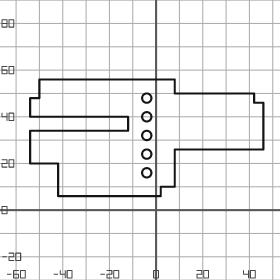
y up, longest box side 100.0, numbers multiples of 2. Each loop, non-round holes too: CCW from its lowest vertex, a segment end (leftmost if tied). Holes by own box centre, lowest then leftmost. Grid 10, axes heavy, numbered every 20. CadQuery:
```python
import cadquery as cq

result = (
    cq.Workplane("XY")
    .moveTo(-42.0, 6.0)
    .lineTo(2.0, 6.0)
    .lineTo(2.0, 10.0)
    .lineTo(8.0, 10.0)
    .lineTo(8.0, 26.0)
    .lineTo(46.0, 26.0)
    .lineTo(46.0, 46.0)
    .lineTo(42.0, 46.0)
    .lineTo(42.0, 50.0)
    .lineTo(8.0, 50.0)
    .lineTo(8.0, 56.0)
    .lineTo(-50.0, 56.0)
    .lineTo(-50.0, 48.0)
    .lineTo(-54.0, 48.0)
    .lineTo(-54.0, 40.0)
    .lineTo(-12.0, 40.0)
    .lineTo(-12.0, 34.0)
    .lineTo(-54.0, 34.0)
    .lineTo(-54.0, 20.0)
    .lineTo(-42.0, 20.0)
    .close()
    .moveTo(-4.0, 16.0)
    .circle(2.0)
    .moveTo(-4.0, 24.0)
    .circle(2.0)
    .moveTo(-4.0, 32.0)
    .circle(2.0)
    .moveTo(-4.0, 40.0)
    .circle(2.0)
    .moveTo(-4.0, 48.0)
    .circle(2.0)
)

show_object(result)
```